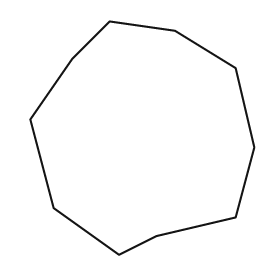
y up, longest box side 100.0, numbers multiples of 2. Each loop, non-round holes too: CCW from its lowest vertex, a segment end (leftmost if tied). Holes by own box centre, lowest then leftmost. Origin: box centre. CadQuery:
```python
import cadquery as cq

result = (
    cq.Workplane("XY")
    .moveTo(-10.0, -50.0)
    .lineTo(6.0, -42.0)
    .lineTo(40.0, -34.0)
    .lineTo(48.0, -4.0)
    .lineTo(40.0, 30.0)
    .lineTo(14.0, 46.0)
    .lineTo(-14.0, 50.0)
    .lineTo(-30.0, 34.0)
    .lineTo(-48.0, 8.0)
    .lineTo(-38.0, -30.0)
    .close()
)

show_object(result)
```